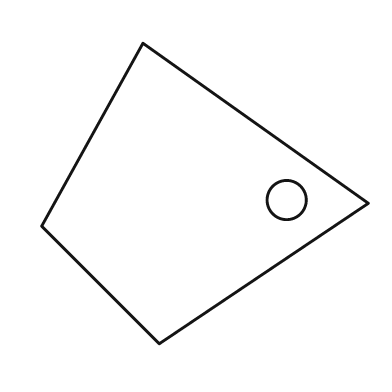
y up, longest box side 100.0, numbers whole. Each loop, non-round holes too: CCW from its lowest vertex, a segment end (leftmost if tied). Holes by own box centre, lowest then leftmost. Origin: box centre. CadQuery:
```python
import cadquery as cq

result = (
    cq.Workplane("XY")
    .moveTo(-14.0, -46.0)
    .lineTo(50.0, -3.0)
    .lineTo(-19.0, 46.0)
    .lineTo(-50.0, -10.0)
    .close()
    .moveTo(25.0, -2.0)
    .circle(6.0)
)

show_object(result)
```